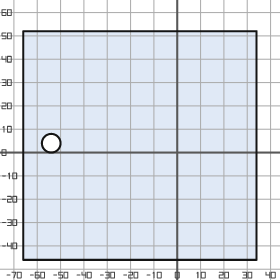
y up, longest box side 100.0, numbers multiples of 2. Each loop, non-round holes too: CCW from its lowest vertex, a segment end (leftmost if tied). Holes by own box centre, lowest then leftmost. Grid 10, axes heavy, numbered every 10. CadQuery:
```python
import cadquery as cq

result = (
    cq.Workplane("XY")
    .moveTo(-66.0, -46.0)
    .lineTo(34.0, -46.0)
    .lineTo(34.0, 52.0)
    .lineTo(-66.0, 52.0)
    .close()
    .moveTo(-54.0, 4.0)
    .circle(4.0)
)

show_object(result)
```